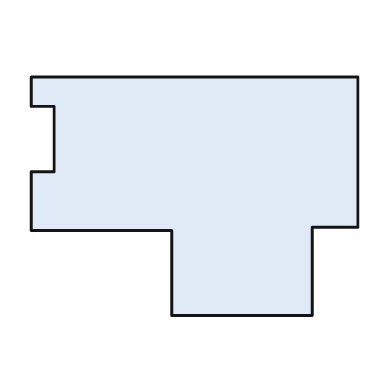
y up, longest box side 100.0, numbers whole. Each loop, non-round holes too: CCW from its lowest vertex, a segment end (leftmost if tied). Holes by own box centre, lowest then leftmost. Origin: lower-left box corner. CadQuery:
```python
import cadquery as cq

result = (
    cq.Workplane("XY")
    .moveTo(43.0, 0.0)
    .lineTo(86.0, 0.0)
    .lineTo(86.0, 27.0)
    .lineTo(100.0, 27.0)
    .lineTo(100.0, 73.0)
    .lineTo(0.0, 73.0)
    .lineTo(0.0, 64.0)
    .lineTo(7.0, 64.0)
    .lineTo(7.0, 44.0)
    .lineTo(0.0, 44.0)
    .lineTo(0.0, 26.0)
    .lineTo(43.0, 26.0)
    .close()
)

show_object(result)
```